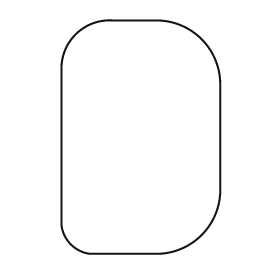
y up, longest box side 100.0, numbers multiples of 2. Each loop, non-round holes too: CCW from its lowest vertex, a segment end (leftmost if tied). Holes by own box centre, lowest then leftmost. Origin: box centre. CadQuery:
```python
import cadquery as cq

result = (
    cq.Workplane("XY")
    .moveTo(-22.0, -50.0)
    .lineTo(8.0, -50.0)
    .threePointArc((26.0, -42.0), (34.0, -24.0))
    .lineTo(34.0, 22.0)
    .threePointArc((26.0, 42.0), (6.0, 50.0))
    .lineTo(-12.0, 50.0)
    .threePointArc((-28.0, 44.0), (-34.0, 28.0))
    .lineTo(-34.0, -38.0)
    .threePointArc((-30.0, -46.0), (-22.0, -50.0))
    .close()
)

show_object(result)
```